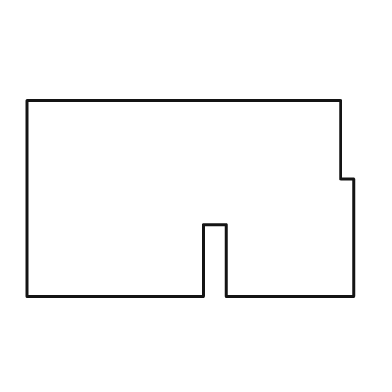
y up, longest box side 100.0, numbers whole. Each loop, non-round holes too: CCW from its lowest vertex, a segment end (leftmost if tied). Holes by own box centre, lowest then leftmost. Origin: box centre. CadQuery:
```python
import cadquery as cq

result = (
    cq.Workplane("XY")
    .moveTo(-50.0, -30.0)
    .lineTo(4.0, -30.0)
    .lineTo(4.0, -8.0)
    .lineTo(11.0, -8.0)
    .lineTo(11.0, -30.0)
    .lineTo(50.0, -30.0)
    .lineTo(50.0, 6.0)
    .lineTo(46.0, 6.0)
    .lineTo(46.0, 30.0)
    .lineTo(-50.0, 30.0)
    .close()
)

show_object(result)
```